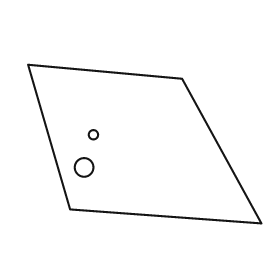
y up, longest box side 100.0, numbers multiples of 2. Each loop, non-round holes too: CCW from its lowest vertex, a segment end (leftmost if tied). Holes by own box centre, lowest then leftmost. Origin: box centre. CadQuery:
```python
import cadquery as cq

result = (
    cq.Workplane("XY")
    .moveTo(50.0, -34.0)
    .lineTo(16.0, 28.0)
    .lineTo(-50.0, 34.0)
    .lineTo(-32.0, -28.0)
    .close()
    .moveTo(-26.0, -10.0)
    .circle(4.0)
    .moveTo(-22.0, 4.0)
    .circle(2.0)
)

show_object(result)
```